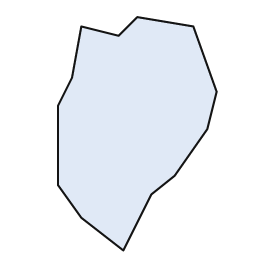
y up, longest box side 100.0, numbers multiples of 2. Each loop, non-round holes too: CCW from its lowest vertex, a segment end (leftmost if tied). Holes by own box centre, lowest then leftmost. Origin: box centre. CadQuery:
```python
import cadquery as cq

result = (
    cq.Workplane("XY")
    .moveTo(-6.0, -50.0)
    .lineTo(6.0, -26.0)
    .lineTo(16.0, -18.0)
    .lineTo(30.0, 2.0)
    .lineTo(34.0, 18.0)
    .lineTo(24.0, 46.0)
    .lineTo(0.0, 50.0)
    .lineTo(-8.0, 42.0)
    .lineTo(-24.0, 46.0)
    .lineTo(-28.0, 24.0)
    .lineTo(-34.0, 12.0)
    .lineTo(-34.0, -22.0)
    .lineTo(-24.0, -36.0)
    .close()
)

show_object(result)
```